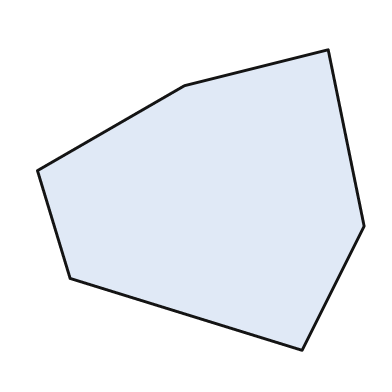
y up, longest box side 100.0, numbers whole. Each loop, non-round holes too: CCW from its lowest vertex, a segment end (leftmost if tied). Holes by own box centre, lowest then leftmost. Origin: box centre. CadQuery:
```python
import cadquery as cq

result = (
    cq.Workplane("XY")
    .moveTo(31.0, -46.0)
    .lineTo(50.0, -8.0)
    .lineTo(39.0, 46.0)
    .lineTo(-5.0, 35.0)
    .lineTo(-50.0, 9.0)
    .lineTo(-40.0, -24.0)
    .close()
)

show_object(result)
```